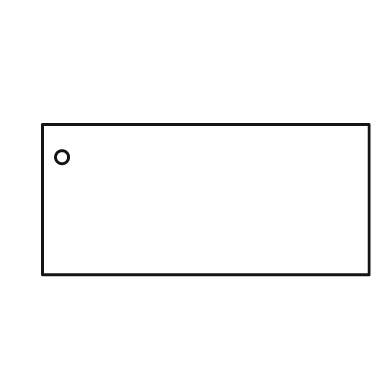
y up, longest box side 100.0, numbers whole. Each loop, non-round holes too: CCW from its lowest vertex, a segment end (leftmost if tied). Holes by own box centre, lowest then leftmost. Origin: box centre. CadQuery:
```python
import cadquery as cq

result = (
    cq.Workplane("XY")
    .moveTo(-50.0, -23.0)
    .lineTo(50.0, -23.0)
    .lineTo(50.0, 23.0)
    .lineTo(-50.0, 23.0)
    .close()
    .moveTo(-44.0, 13.0)
    .circle(2.0)
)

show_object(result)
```